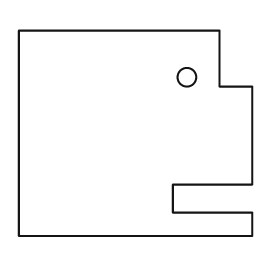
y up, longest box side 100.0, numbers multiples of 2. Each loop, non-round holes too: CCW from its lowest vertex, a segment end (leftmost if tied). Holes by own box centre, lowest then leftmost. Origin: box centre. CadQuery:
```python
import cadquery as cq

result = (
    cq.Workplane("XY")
    .moveTo(-50.0, -44.0)
    .lineTo(50.0, -44.0)
    .lineTo(50.0, -34.0)
    .lineTo(16.0, -34.0)
    .lineTo(16.0, -22.0)
    .lineTo(50.0, -22.0)
    .lineTo(50.0, 20.0)
    .lineTo(36.0, 20.0)
    .lineTo(36.0, 44.0)
    .lineTo(-50.0, 44.0)
    .close()
    .moveTo(22.0, 24.0)
    .circle(4.0)
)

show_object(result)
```